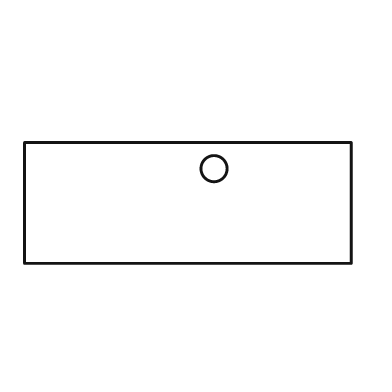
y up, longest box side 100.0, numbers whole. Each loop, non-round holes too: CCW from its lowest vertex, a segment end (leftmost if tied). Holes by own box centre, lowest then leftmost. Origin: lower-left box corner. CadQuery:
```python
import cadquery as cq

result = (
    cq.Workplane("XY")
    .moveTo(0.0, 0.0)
    .lineTo(100.0, 0.0)
    .lineTo(100.0, 37.0)
    .lineTo(0.0, 37.0)
    .close()
    .moveTo(58.0, 29.0)
    .circle(4.0)
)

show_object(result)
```